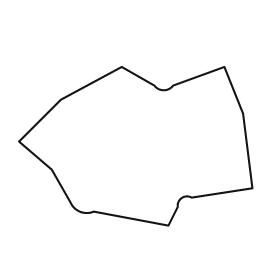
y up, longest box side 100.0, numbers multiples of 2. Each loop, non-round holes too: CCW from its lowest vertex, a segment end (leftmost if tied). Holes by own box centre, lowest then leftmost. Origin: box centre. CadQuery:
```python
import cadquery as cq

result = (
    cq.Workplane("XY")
    .moveTo(14.0, -34.0)
    .lineTo(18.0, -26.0)
    .threePointArc((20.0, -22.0), (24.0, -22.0))
    .lineTo(50.0, -18.0)
    .lineTo(46.0, 14.0)
    .lineTo(38.0, 34.0)
    .lineTo(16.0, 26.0)
    .threePointArc((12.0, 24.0), (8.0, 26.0))
    .lineTo(-6.0, 34.0)
    .lineTo(-32.0, 20.0)
    .lineTo(-50.0, 2.0)
    .lineTo(-36.0, -10.0)
    .lineTo(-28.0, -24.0)
    .threePointArc((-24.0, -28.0), (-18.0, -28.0))
    .close()
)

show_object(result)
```